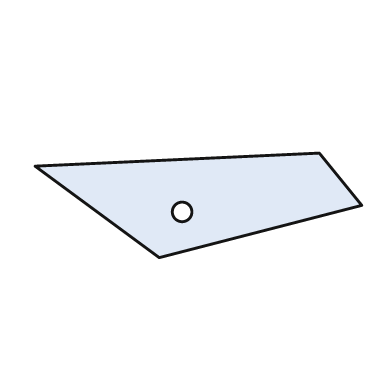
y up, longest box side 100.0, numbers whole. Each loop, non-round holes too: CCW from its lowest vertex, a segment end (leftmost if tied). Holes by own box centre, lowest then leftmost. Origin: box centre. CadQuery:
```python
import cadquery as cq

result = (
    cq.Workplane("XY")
    .moveTo(-12.0, -16.0)
    .lineTo(50.0, 0.0)
    .lineTo(37.0, 16.0)
    .lineTo(-50.0, 12.0)
    .close()
    .moveTo(-5.0, -2.0)
    .circle(3.0)
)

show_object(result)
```